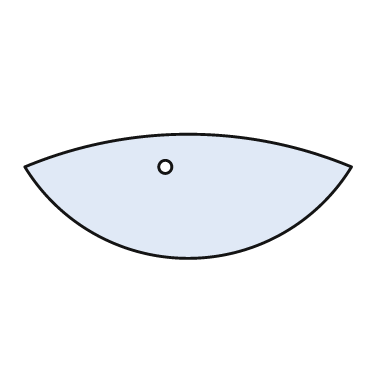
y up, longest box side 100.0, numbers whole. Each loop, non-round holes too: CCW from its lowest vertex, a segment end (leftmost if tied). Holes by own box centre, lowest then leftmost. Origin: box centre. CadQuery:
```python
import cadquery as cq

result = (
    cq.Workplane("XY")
    .moveTo(-50.0, 9.0)
    .threePointArc((0.0, -19.0), (50.0, 9.0))
    .threePointArc((0.0, 19.0), (-50.0, 9.0))
    .close()
    .moveTo(-7.0, 9.0)
    .circle(2.0)
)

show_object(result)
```